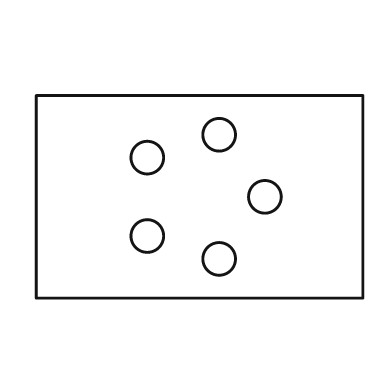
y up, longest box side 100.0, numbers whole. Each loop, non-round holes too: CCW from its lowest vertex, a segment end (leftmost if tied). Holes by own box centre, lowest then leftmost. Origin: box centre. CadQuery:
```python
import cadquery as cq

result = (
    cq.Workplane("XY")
    .moveTo(-50.0, -31.0)
    .lineTo(50.0, -31.0)
    .lineTo(50.0, 31.0)
    .lineTo(-50.0, 31.0)
    .close()
    .moveTo(6.0, -19.0)
    .circle(5.0)
    .moveTo(-16.0, -12.0)
    .circle(5.0)
    .moveTo(20.0, 0.0)
    .circle(5.0)
    .moveTo(-16.0, 12.0)
    .circle(5.0)
    .moveTo(6.0, 19.0)
    .circle(5.0)
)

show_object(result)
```